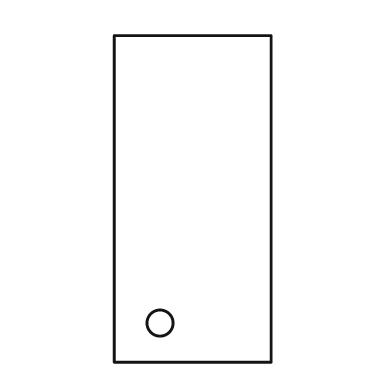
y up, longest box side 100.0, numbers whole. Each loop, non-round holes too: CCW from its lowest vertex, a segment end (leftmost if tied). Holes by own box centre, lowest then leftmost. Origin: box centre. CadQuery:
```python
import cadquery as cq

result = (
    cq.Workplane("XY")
    .moveTo(-24.0, -50.0)
    .lineTo(24.0, -50.0)
    .lineTo(24.0, 50.0)
    .lineTo(-24.0, 50.0)
    .close()
    .moveTo(-10.0, -38.0)
    .circle(4.0)
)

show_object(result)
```